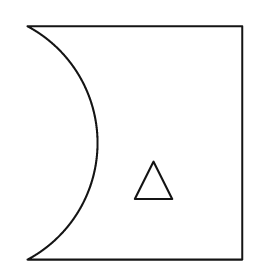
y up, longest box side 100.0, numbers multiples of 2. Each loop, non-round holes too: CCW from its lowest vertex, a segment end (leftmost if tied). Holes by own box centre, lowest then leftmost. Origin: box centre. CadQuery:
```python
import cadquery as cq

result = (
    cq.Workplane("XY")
    .moveTo(-46.0, -50.0)
    .lineTo(46.0, -50.0)
    .lineTo(46.0, 50.0)
    .lineTo(-46.0, 50.0)
    .threePointArc((-16.0, 0.0), (-46.0, -50.0))
    .close()
    .moveTo(0.0, -24.0)
    .lineTo(16.0, -24.0)
    .lineTo(8.0, -8.0)
    .close()
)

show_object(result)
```